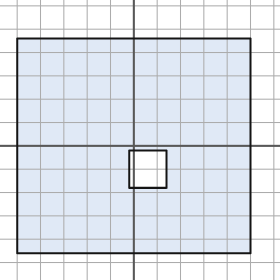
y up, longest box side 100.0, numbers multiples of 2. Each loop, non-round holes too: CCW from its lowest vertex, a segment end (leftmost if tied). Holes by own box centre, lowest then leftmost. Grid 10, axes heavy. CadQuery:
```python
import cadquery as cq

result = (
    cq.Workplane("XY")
    .moveTo(-50.0, -46.0)
    .lineTo(50.0, -46.0)
    .lineTo(50.0, 46.0)
    .lineTo(-50.0, 46.0)
    .close()
    .moveTo(-2.0, -18.0)
    .lineTo(14.0, -18.0)
    .lineTo(14.0, -2.0)
    .lineTo(-2.0, -2.0)
    .close()
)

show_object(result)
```